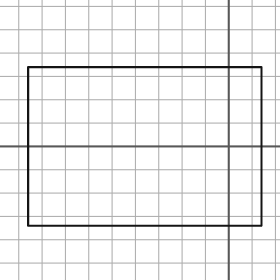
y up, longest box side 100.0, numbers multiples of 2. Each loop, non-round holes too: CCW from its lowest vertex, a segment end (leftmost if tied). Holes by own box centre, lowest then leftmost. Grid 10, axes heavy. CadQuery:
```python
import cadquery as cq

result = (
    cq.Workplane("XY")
    .moveTo(-86.0, -34.0)
    .lineTo(14.0, -34.0)
    .lineTo(14.0, 34.0)
    .lineTo(-86.0, 34.0)
    .close()
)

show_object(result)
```